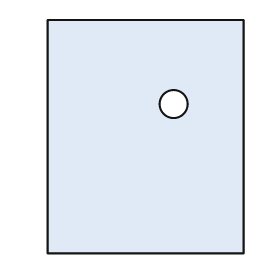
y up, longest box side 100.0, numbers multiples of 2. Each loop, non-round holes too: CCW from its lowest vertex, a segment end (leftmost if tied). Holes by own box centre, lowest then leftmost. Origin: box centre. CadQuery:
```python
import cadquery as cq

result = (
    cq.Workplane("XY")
    .moveTo(-42.0, -50.0)
    .lineTo(42.0, -50.0)
    .lineTo(42.0, 50.0)
    .lineTo(-42.0, 50.0)
    .close()
    .moveTo(12.0, 14.0)
    .circle(6.0)
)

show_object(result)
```